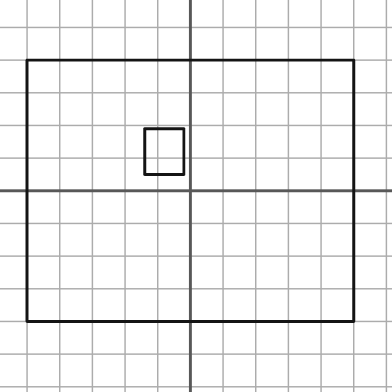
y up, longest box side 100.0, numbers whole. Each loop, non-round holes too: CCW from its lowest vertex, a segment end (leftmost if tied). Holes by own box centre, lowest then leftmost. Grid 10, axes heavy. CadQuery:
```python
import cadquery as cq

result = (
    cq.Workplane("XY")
    .moveTo(-50.0, -40.0)
    .lineTo(50.0, -40.0)
    .lineTo(50.0, 40.0)
    .lineTo(-50.0, 40.0)
    .close()
    .moveTo(-14.0, 5.0)
    .lineTo(-2.0, 5.0)
    .lineTo(-2.0, 19.0)
    .lineTo(-14.0, 19.0)
    .close()
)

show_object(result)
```